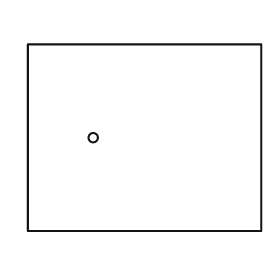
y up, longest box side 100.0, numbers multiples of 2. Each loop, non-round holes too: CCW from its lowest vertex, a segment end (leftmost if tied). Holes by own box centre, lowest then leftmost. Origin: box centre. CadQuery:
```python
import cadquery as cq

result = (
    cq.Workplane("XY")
    .moveTo(-50.0, -40.0)
    .lineTo(50.0, -40.0)
    .lineTo(50.0, 40.0)
    .lineTo(-50.0, 40.0)
    .close()
    .moveTo(-22.0, 0.0)
    .circle(2.0)
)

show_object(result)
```